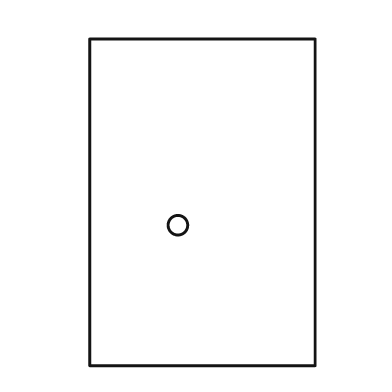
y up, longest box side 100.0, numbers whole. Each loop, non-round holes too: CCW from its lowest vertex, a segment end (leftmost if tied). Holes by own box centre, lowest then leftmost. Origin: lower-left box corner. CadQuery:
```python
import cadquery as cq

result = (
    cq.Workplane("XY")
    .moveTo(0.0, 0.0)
    .lineTo(69.0, 0.0)
    .lineTo(69.0, 100.0)
    .lineTo(0.0, 100.0)
    .close()
    .moveTo(27.0, 43.0)
    .circle(3.0)
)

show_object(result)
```